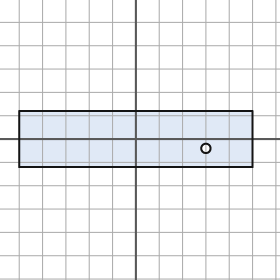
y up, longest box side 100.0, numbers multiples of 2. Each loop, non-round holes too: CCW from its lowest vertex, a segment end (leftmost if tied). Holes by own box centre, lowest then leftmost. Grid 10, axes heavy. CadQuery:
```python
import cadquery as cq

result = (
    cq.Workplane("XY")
    .moveTo(-50.0, -12.0)
    .lineTo(50.0, -12.0)
    .lineTo(50.0, 12.0)
    .lineTo(-50.0, 12.0)
    .close()
    .moveTo(30.0, -4.0)
    .circle(2.0)
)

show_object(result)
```